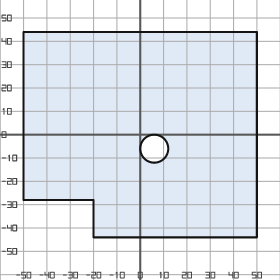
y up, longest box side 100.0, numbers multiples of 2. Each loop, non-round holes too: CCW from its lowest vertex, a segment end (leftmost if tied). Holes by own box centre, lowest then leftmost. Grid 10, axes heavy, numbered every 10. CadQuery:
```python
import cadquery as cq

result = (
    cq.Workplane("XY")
    .moveTo(-20.0, -44.0)
    .lineTo(50.0, -44.0)
    .lineTo(50.0, 44.0)
    .lineTo(-50.0, 44.0)
    .lineTo(-50.0, -28.0)
    .lineTo(-20.0, -28.0)
    .close()
    .moveTo(6.0, -6.0)
    .circle(6.0)
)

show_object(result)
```